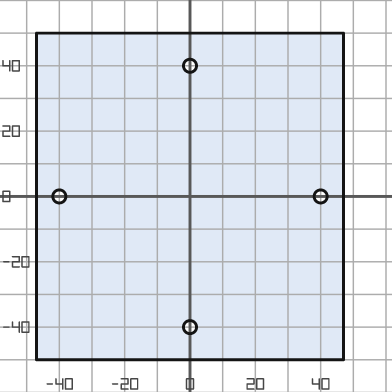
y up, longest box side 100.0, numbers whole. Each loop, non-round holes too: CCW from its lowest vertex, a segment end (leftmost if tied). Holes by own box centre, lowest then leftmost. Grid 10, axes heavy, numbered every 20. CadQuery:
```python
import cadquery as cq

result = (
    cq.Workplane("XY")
    .moveTo(-47.0, -50.0)
    .lineTo(47.0, -50.0)
    .lineTo(47.0, 50.0)
    .lineTo(-47.0, 50.0)
    .close()
    .moveTo(0.0, -40.0)
    .circle(2.0)
    .moveTo(-40.0, 0.0)
    .circle(2.0)
    .moveTo(40.0, 0.0)
    .circle(2.0)
    .moveTo(0.0, 40.0)
    .circle(2.0)
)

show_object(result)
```